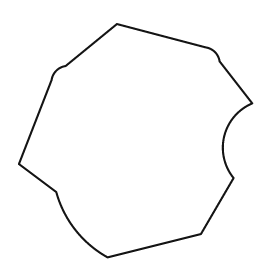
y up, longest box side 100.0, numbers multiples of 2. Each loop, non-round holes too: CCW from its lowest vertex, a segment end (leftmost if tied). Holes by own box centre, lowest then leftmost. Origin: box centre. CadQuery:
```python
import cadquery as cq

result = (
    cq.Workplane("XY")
    .moveTo(-12.0, -50.0)
    .lineTo(28.0, -40.0)
    .lineTo(42.0, -16.0)
    .threePointArc((38.0, 2.0), (50.0, 16.0))
    .lineTo(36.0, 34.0)
    .threePointArc((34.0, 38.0), (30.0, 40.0))
    .lineTo(-8.0, 50.0)
    .lineTo(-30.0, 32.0)
    .threePointArc((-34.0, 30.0), (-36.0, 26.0))
    .lineTo(-50.0, -10.0)
    .lineTo(-34.0, -22.0)
    .threePointArc((-26.0, -38.0), (-12.0, -50.0))
    .close()
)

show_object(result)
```